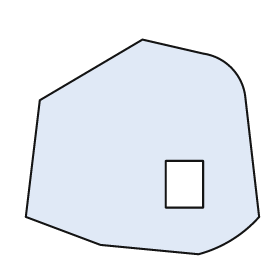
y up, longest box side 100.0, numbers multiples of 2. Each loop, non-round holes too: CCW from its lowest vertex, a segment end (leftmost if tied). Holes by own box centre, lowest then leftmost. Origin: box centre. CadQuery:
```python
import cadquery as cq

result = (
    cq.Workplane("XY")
    .moveTo(24.0, -46.0)
    .threePointArc((38.0, -40.0), (50.0, -30.0))
    .lineTo(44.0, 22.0)
    .threePointArc((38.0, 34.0), (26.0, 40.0))
    .lineTo(0.0, 46.0)
    .lineTo(-44.0, 20.0)
    .lineTo(-50.0, -30.0)
    .lineTo(-18.0, -42.0)
    .close()
    .moveTo(10.0, -26.0)
    .lineTo(26.0, -26.0)
    .lineTo(26.0, -6.0)
    .lineTo(10.0, -6.0)
    .close()
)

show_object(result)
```